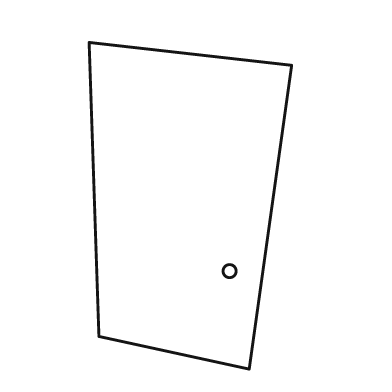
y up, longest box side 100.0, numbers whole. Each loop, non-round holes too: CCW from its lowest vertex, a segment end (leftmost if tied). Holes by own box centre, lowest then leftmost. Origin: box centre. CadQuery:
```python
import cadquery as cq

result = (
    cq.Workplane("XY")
    .moveTo(18.0, -50.0)
    .lineTo(31.0, 43.0)
    .lineTo(-31.0, 50.0)
    .lineTo(-28.0, -40.0)
    .close()
    .moveTo(12.0, -20.0)
    .circle(2.0)
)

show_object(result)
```